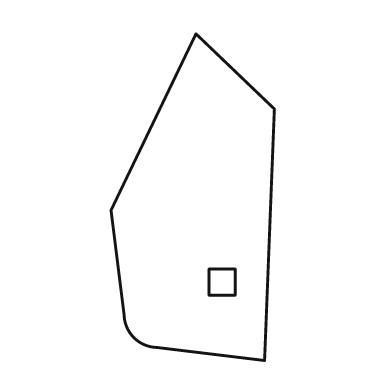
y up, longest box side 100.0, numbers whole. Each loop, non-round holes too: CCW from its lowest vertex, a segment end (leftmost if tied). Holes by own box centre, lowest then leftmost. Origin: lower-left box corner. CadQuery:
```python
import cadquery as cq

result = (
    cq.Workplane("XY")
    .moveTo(47.0, 0.0)
    .lineTo(50.0, 77.0)
    .lineTo(26.0, 100.0)
    .lineTo(0.0, 46.0)
    .lineTo(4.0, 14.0)
    .threePointArc((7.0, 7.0), (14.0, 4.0))
    .close()
    .moveTo(30.0, 20.0)
    .lineTo(38.0, 20.0)
    .lineTo(38.0, 28.0)
    .lineTo(30.0, 28.0)
    .close()
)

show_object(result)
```